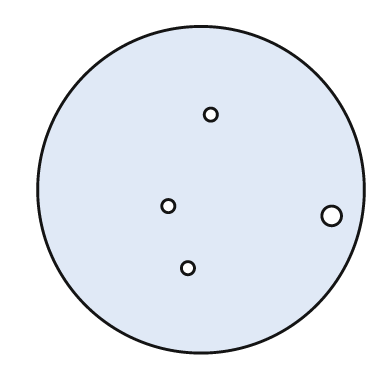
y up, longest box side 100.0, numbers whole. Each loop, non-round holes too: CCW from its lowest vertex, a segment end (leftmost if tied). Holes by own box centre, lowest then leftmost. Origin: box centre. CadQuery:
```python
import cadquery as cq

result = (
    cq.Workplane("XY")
    .moveTo(0.0, 0.0)
    .circle(50.0)
    .moveTo(-4.0, -24.0)
    .circle(2.0)
    .moveTo(40.0, -8.0)
    .circle(3.0)
    .moveTo(-10.0, -5.0)
    .circle(2.0)
    .moveTo(3.0, 23.0)
    .circle(2.0)
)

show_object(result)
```